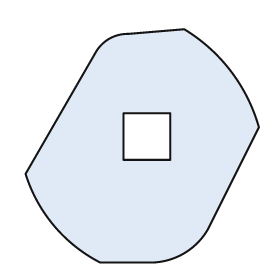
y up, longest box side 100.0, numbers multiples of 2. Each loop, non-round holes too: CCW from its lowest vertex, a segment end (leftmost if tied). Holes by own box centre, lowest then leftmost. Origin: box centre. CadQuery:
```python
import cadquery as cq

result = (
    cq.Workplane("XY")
    .moveTo(-18.0, -50.0)
    .lineTo(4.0, -50.0)
    .threePointArc((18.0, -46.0), (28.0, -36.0))
    .lineTo(50.0, 8.0)
    .threePointArc((38.0, 32.0), (18.0, 50.0))
    .lineTo(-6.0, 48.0)
    .threePointArc((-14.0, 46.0), (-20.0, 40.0))
    .lineTo(-50.0, -12.0)
    .threePointArc((-38.0, -34.0), (-18.0, -50.0))
    .close()
    .moveTo(-8.0, -6.0)
    .lineTo(12.0, -6.0)
    .lineTo(12.0, 14.0)
    .lineTo(-8.0, 14.0)
    .close()
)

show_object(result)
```